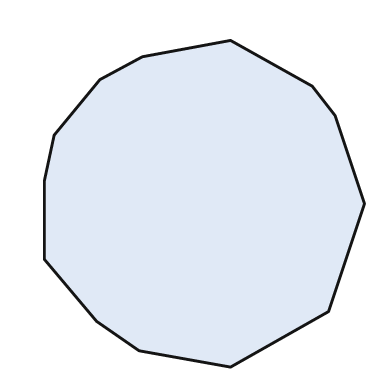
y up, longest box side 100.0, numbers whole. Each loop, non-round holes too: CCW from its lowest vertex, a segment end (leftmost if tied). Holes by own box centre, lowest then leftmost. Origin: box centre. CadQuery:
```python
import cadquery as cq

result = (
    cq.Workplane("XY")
    .moveTo(8.0, -50.0)
    .lineTo(38.0, -33.0)
    .lineTo(49.0, 0.0)
    .lineTo(40.0, 27.0)
    .lineTo(33.0, 36.0)
    .lineTo(8.0, 50.0)
    .lineTo(-19.0, 45.0)
    .lineTo(-32.0, 38.0)
    .lineTo(-46.0, 21.0)
    .lineTo(-49.0, 7.0)
    .lineTo(-49.0, -17.0)
    .lineTo(-33.0, -36.0)
    .lineTo(-20.0, -45.0)
    .close()
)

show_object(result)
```